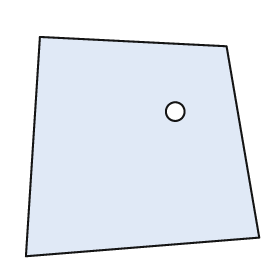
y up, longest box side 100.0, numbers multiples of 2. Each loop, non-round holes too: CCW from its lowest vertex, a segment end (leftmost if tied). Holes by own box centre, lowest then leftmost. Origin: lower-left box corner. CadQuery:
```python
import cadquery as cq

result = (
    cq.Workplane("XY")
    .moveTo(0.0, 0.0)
    .lineTo(100.0, 8.0)
    .lineTo(86.0, 90.0)
    .lineTo(6.0, 94.0)
    .close()
    .moveTo(64.0, 62.0)
    .circle(4.0)
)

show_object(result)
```